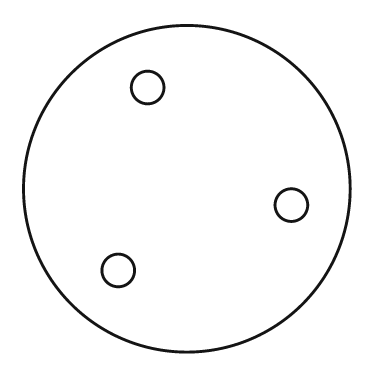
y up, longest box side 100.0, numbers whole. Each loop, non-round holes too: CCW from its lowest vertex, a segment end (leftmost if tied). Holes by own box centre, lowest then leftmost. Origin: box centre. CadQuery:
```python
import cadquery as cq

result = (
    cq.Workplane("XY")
    .moveTo(0.0, 0.0)
    .circle(50.0)
    .moveTo(-21.0, -25.0)
    .circle(5.0)
    .moveTo(32.0, -5.0)
    .circle(5.0)
    .moveTo(-12.0, 31.0)
    .circle(5.0)
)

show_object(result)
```